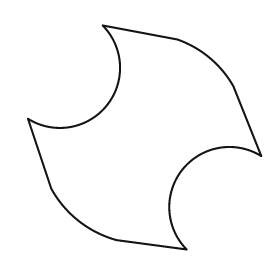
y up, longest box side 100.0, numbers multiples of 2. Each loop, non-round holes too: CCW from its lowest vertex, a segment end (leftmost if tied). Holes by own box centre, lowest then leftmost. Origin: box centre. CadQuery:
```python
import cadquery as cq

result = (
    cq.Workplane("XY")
    .moveTo(18.0, -48.0)
    .threePointArc((16.0, -14.0), (50.0, -8.0))
    .lineTo(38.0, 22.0)
    .threePointArc((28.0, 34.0), (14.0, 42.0))
    .lineTo(-18.0, 48.0)
    .threePointArc((-16.0, 14.0), (-50.0, 8.0))
    .lineTo(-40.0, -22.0)
    .threePointArc((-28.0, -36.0), (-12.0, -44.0))
    .close()
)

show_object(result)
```